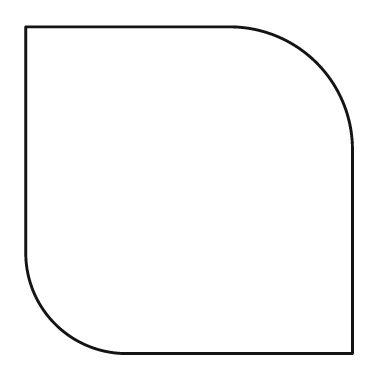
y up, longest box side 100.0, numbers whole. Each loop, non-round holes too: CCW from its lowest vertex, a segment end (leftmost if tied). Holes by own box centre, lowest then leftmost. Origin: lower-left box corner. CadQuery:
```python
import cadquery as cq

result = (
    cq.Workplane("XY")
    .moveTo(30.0, 0.0)
    .lineTo(100.0, 0.0)
    .lineTo(100.0, 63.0)
    .threePointArc((89.0, 89.0), (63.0, 100.0))
    .lineTo(0.0, 100.0)
    .lineTo(0.0, 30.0)
    .threePointArc((9.0, 9.0), (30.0, 0.0))
    .close()
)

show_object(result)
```